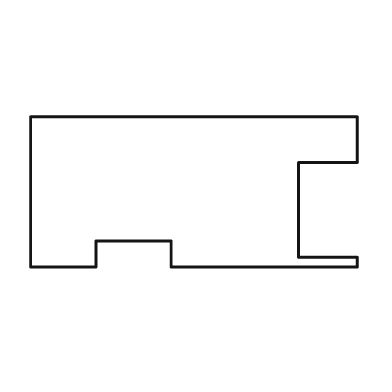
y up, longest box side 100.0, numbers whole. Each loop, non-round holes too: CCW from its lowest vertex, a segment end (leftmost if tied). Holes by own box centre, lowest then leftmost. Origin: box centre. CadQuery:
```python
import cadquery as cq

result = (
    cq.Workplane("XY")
    .moveTo(-50.0, -23.0)
    .lineTo(-30.0, -23.0)
    .lineTo(-30.0, -15.0)
    .lineTo(-7.0, -15.0)
    .lineTo(-7.0, -23.0)
    .lineTo(50.0, -23.0)
    .lineTo(50.0, -20.0)
    .lineTo(32.0, -20.0)
    .lineTo(32.0, 9.0)
    .lineTo(50.0, 9.0)
    .lineTo(50.0, 23.0)
    .lineTo(-50.0, 23.0)
    .close()
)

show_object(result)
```